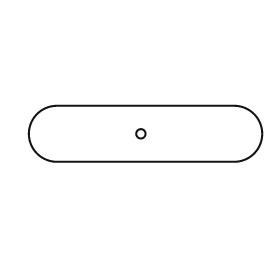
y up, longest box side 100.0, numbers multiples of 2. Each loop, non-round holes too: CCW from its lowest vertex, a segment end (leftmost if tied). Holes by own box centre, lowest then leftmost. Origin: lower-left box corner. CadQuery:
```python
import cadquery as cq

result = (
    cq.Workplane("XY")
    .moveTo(12.0, 0.0)
    .lineTo(88.0, 0.0)
    .threePointArc((100.0, 12.0), (88.0, 24.0))
    .lineTo(12.0, 24.0)
    .threePointArc((0.0, 12.0), (12.0, 0.0))
    .close()
    .moveTo(48.0, 12.0)
    .circle(2.0)
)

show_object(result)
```